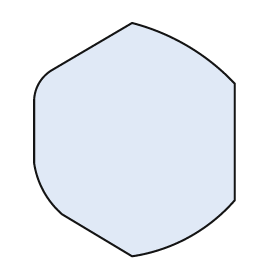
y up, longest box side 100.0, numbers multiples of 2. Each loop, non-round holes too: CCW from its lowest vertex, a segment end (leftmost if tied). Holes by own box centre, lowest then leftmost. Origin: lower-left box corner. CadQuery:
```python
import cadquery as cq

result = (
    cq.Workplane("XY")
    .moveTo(42.0, 0.0)
    .threePointArc((66.0, 8.0), (86.0, 24.0))
    .lineTo(86.0, 74.0)
    .threePointArc((66.0, 90.0), (42.0, 100.0))
    .lineTo(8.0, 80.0)
    .threePointArc((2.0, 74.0), (0.0, 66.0))
    .lineTo(0.0, 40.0)
    .threePointArc((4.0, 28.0), (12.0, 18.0))
    .close()
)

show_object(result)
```